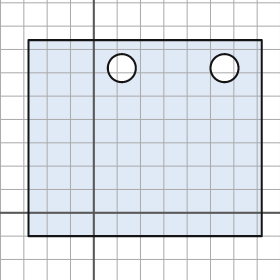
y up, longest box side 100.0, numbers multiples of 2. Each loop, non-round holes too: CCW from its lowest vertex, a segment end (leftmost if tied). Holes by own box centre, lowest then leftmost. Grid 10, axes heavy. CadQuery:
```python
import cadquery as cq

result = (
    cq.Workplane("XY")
    .moveTo(-28.0, -10.0)
    .lineTo(72.0, -10.0)
    .lineTo(72.0, 74.0)
    .lineTo(-28.0, 74.0)
    .close()
    .moveTo(12.0, 62.0)
    .circle(6.0)
    .moveTo(56.0, 62.0)
    .circle(6.0)
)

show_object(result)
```